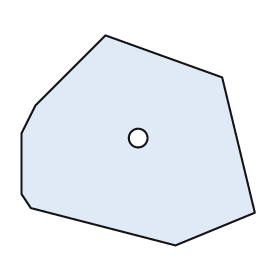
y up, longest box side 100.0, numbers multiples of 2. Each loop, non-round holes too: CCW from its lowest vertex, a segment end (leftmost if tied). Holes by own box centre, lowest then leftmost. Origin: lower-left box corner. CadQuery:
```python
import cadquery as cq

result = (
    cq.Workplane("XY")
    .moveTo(66.0, 0.0)
    .lineTo(100.0, 14.0)
    .lineTo(86.0, 72.0)
    .lineTo(36.0, 90.0)
    .lineTo(6.0, 60.0)
    .lineTo(0.0, 48.0)
    .lineTo(0.0, 22.0)
    .lineTo(4.0, 16.0)
    .close()
    .moveTo(50.0, 46.0)
    .circle(4.0)
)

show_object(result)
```